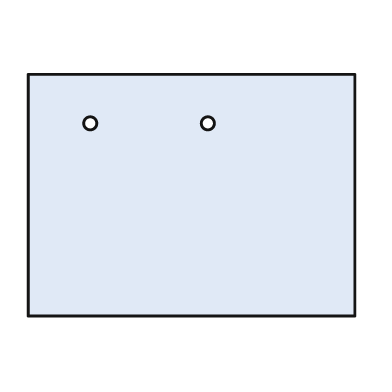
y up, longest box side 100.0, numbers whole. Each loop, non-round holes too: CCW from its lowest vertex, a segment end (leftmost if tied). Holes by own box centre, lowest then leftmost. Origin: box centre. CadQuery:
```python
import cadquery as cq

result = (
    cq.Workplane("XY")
    .moveTo(-50.0, -37.0)
    .lineTo(50.0, -37.0)
    .lineTo(50.0, 37.0)
    .lineTo(-50.0, 37.0)
    .close()
    .moveTo(-31.0, 22.0)
    .circle(2.0)
    .moveTo(5.0, 22.0)
    .circle(2.0)
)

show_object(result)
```